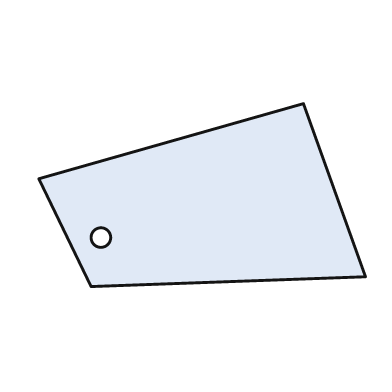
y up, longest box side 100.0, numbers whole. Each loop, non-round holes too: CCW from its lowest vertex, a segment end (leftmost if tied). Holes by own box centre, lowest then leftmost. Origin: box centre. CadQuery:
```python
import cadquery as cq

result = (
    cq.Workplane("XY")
    .moveTo(-34.0, -28.0)
    .lineTo(50.0, -25.0)
    .lineTo(31.0, 28.0)
    .lineTo(-50.0, 5.0)
    .close()
    .moveTo(-31.0, -13.0)
    .circle(3.0)
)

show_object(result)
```